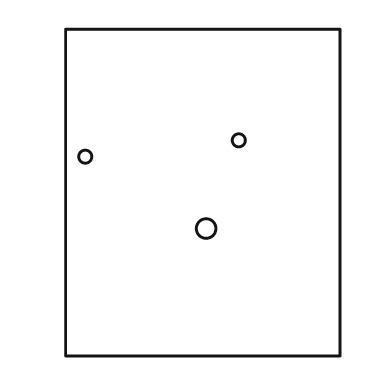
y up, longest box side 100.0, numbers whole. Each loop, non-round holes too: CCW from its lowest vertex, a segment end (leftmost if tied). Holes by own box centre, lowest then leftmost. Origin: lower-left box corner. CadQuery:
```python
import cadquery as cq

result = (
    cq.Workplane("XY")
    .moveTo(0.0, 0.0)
    .lineTo(84.0, 0.0)
    .lineTo(84.0, 100.0)
    .lineTo(0.0, 100.0)
    .close()
    .moveTo(43.0, 39.0)
    .circle(3.0)
    .moveTo(6.0, 61.0)
    .circle(2.0)
    .moveTo(53.0, 66.0)
    .circle(2.0)
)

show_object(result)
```